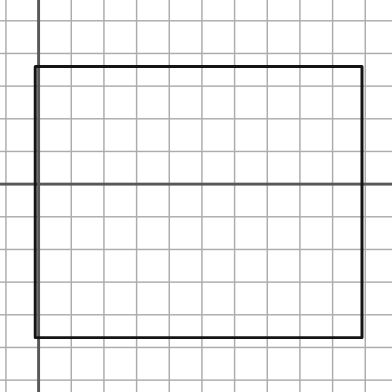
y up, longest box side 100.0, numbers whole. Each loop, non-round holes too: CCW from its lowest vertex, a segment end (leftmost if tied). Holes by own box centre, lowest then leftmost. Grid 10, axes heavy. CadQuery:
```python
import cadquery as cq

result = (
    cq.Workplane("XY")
    .moveTo(-1.0, -47.0)
    .lineTo(99.0, -47.0)
    .lineTo(99.0, 36.0)
    .lineTo(-1.0, 36.0)
    .close()
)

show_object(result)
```